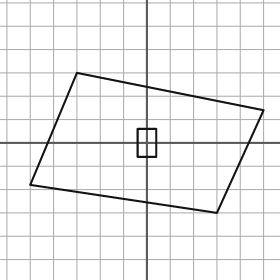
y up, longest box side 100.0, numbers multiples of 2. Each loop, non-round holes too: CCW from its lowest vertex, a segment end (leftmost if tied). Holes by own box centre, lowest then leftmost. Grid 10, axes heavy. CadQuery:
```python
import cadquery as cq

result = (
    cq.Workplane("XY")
    .moveTo(30.0, -30.0)
    .lineTo(50.0, 14.0)
    .lineTo(-30.0, 30.0)
    .lineTo(-50.0, -18.0)
    .close()
    .moveTo(-4.0, -6.0)
    .lineTo(4.0, -6.0)
    .lineTo(4.0, 6.0)
    .lineTo(-4.0, 6.0)
    .close()
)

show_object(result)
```